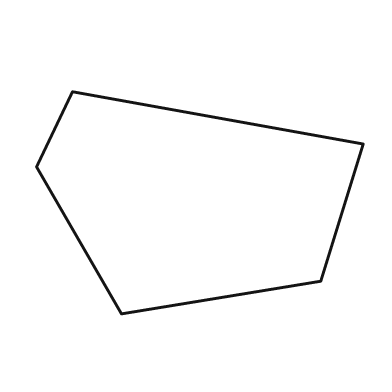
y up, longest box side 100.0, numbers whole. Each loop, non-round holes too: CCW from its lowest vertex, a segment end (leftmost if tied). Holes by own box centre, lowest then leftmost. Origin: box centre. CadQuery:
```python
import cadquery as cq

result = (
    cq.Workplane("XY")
    .moveTo(-24.0, -34.0)
    .lineTo(37.0, -24.0)
    .lineTo(50.0, 18.0)
    .lineTo(-39.0, 34.0)
    .lineTo(-50.0, 11.0)
    .close()
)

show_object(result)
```